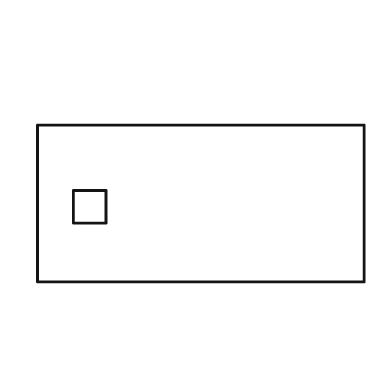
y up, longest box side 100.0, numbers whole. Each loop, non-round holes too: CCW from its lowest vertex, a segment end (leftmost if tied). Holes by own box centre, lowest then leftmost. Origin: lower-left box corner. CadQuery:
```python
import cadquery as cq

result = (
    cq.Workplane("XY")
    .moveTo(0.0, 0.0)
    .lineTo(100.0, 0.0)
    .lineTo(100.0, 48.0)
    .lineTo(0.0, 48.0)
    .close()
    .moveTo(11.0, 18.0)
    .lineTo(21.0, 18.0)
    .lineTo(21.0, 28.0)
    .lineTo(11.0, 28.0)
    .close()
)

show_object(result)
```